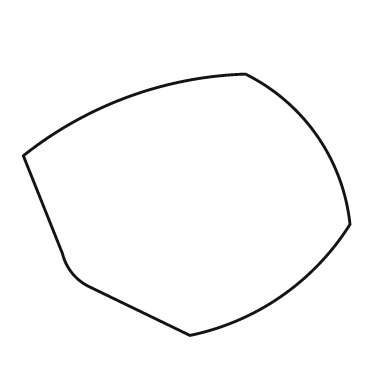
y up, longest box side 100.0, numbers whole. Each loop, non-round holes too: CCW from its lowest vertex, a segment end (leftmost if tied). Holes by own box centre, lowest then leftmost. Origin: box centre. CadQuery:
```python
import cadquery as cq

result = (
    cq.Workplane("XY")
    .moveTo(1.0, -40.0)
    .threePointArc((29.0, -28.0), (50.0, -6.0))
    .threePointArc((40.0, 21.0), (18.0, 40.0))
    .threePointArc((-18.0, 33.0), (-50.0, 15.0))
    .lineTo(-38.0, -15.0)
    .threePointArc((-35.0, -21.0), (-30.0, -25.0))
    .close()
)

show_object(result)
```